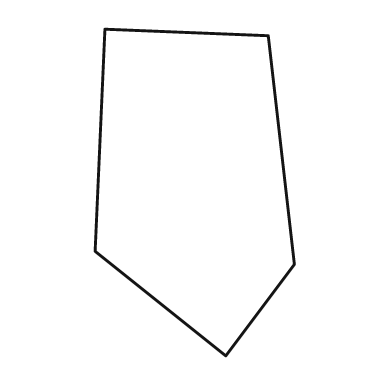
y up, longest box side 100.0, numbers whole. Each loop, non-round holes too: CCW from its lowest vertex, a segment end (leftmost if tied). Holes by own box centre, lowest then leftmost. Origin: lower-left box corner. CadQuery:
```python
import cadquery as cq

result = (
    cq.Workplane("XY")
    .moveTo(40.0, 0.0)
    .lineTo(61.0, 28.0)
    .lineTo(53.0, 98.0)
    .lineTo(3.0, 100.0)
    .lineTo(0.0, 32.0)
    .close()
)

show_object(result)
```